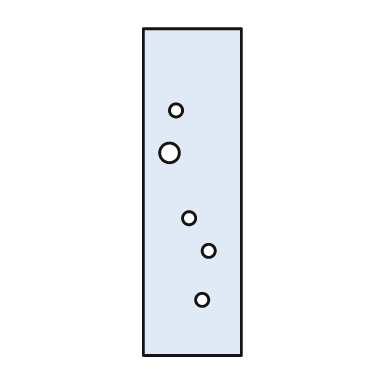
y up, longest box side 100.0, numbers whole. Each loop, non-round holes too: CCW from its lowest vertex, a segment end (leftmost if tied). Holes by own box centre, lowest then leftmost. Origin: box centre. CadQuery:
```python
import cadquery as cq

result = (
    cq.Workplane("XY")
    .moveTo(-15.0, -50.0)
    .lineTo(15.0, -50.0)
    .lineTo(15.0, 50.0)
    .lineTo(-15.0, 50.0)
    .close()
    .moveTo(3.0, -33.0)
    .circle(2.0)
    .moveTo(5.0, -18.0)
    .circle(2.0)
    .moveTo(-1.0, -8.0)
    .circle(2.0)
    .moveTo(-7.0, 12.0)
    .circle(3.0)
    .moveTo(-5.0, 25.0)
    .circle(2.0)
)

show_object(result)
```